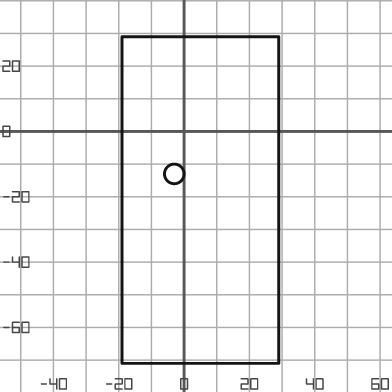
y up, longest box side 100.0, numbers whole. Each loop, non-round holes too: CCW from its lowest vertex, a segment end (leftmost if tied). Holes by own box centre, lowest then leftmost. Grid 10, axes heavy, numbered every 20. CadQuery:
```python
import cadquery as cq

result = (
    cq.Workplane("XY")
    .moveTo(-19.0, -71.0)
    .lineTo(29.0, -71.0)
    .lineTo(29.0, 29.0)
    .lineTo(-19.0, 29.0)
    .close()
    .moveTo(-3.0, -13.0)
    .circle(3.0)
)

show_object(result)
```